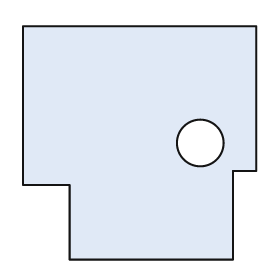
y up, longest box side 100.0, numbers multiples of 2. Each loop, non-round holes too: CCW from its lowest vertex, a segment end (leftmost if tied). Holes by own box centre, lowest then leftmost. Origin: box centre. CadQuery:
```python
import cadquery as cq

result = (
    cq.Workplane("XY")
    .moveTo(-30.0, -50.0)
    .lineTo(40.0, -50.0)
    .lineTo(40.0, -12.0)
    .lineTo(50.0, -12.0)
    .lineTo(50.0, 50.0)
    .lineTo(-50.0, 50.0)
    .lineTo(-50.0, -18.0)
    .lineTo(-30.0, -18.0)
    .close()
    .moveTo(26.0, 0.0)
    .circle(10.0)
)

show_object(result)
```